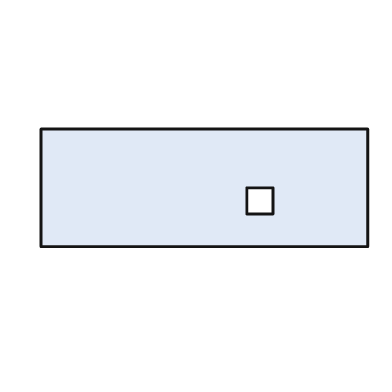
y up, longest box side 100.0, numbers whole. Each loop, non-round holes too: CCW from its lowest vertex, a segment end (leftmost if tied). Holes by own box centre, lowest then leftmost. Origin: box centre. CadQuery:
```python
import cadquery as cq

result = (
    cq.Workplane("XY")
    .moveTo(-50.0, -18.0)
    .lineTo(50.0, -18.0)
    .lineTo(50.0, 18.0)
    .lineTo(-50.0, 18.0)
    .close()
    .moveTo(13.0, -8.0)
    .lineTo(21.0, -8.0)
    .lineTo(21.0, 0.0)
    .lineTo(13.0, 0.0)
    .close()
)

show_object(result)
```